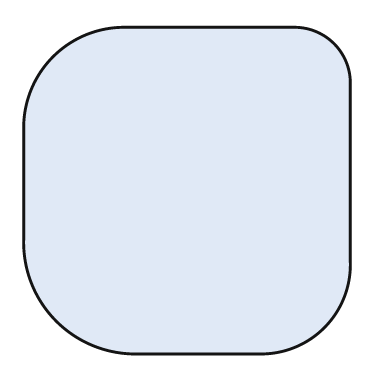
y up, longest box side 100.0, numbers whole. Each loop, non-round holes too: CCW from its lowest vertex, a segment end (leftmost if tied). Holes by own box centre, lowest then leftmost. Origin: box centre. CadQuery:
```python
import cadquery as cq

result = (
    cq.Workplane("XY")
    .moveTo(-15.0, -50.0)
    .lineTo(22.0, -50.0)
    .threePointArc((42.0, -42.0), (50.0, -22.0))
    .lineTo(50.0, 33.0)
    .threePointArc((45.0, 45.0), (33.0, 50.0))
    .lineTo(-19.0, 50.0)
    .threePointArc((-41.0, 41.0), (-50.0, 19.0))
    .lineTo(-50.0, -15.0)
    .threePointArc((-40.0, -40.0), (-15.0, -50.0))
    .close()
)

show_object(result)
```